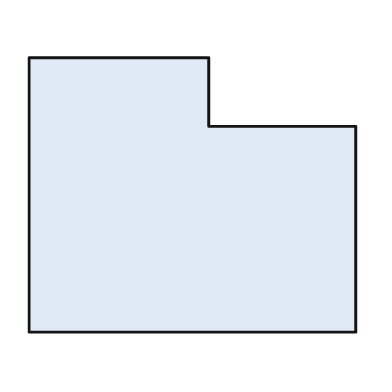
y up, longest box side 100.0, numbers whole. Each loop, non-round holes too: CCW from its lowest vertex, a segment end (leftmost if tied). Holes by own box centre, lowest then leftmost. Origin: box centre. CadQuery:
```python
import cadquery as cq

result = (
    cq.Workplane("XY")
    .moveTo(-50.0, -42.0)
    .lineTo(50.0, -42.0)
    .lineTo(50.0, 21.0)
    .lineTo(5.0, 21.0)
    .lineTo(5.0, 42.0)
    .lineTo(-50.0, 42.0)
    .close()
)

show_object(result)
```